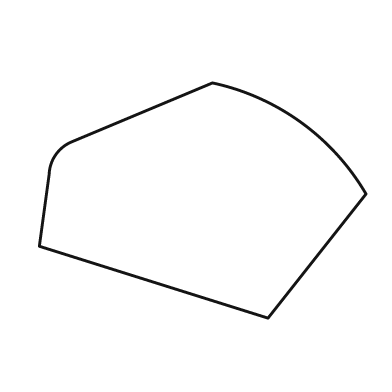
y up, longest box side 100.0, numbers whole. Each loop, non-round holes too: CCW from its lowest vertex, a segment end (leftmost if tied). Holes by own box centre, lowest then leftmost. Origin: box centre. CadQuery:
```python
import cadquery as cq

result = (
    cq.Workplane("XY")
    .moveTo(20.0, -36.0)
    .lineTo(50.0, 2.0)
    .threePointArc((30.0, 24.0), (3.0, 36.0))
    .lineTo(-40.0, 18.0)
    .threePointArc((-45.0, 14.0), (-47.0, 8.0))
    .lineTo(-50.0, -14.0)
    .close()
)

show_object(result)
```